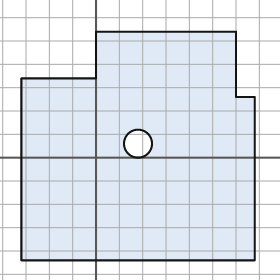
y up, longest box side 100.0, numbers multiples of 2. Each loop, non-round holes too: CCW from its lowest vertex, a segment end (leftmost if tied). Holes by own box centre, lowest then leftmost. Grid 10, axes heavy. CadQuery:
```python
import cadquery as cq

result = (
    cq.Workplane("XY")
    .moveTo(-32.0, -44.0)
    .lineTo(68.0, -44.0)
    .lineTo(68.0, 26.0)
    .lineTo(60.0, 26.0)
    .lineTo(60.0, 54.0)
    .lineTo(0.0, 54.0)
    .lineTo(0.0, 34.0)
    .lineTo(-32.0, 34.0)
    .close()
    .moveTo(18.0, 6.0)
    .circle(6.0)
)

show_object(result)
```